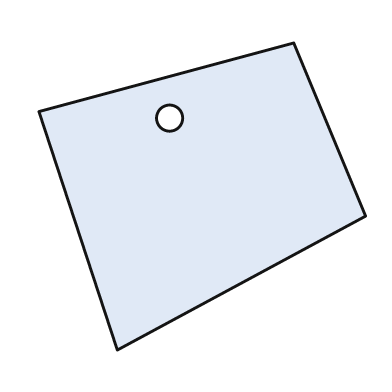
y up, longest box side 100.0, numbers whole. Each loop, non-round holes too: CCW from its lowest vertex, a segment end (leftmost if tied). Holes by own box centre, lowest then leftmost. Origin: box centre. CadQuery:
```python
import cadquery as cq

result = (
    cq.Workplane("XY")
    .moveTo(-26.0, -47.0)
    .lineTo(50.0, -6.0)
    .lineTo(28.0, 47.0)
    .lineTo(-50.0, 26.0)
    .close()
    .moveTo(-10.0, 24.0)
    .circle(4.0)
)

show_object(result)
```